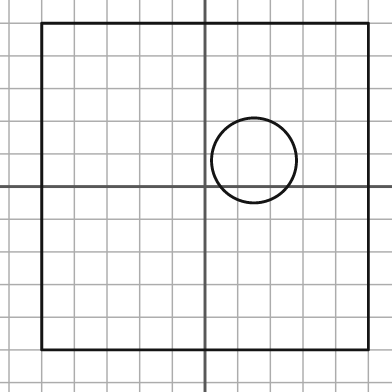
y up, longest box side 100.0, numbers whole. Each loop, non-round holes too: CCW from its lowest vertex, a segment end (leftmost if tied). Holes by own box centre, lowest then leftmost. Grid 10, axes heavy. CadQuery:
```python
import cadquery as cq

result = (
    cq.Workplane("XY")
    .moveTo(-50.0, -50.0)
    .lineTo(50.0, -50.0)
    .lineTo(50.0, 50.0)
    .lineTo(-50.0, 50.0)
    .close()
    .moveTo(15.0, 8.0)
    .circle(13.0)
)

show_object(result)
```